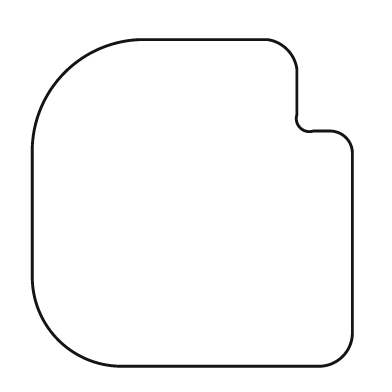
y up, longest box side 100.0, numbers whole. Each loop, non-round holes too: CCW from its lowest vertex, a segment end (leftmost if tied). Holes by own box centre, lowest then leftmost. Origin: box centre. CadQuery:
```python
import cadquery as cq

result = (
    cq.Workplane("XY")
    .moveTo(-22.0, -50.0)
    .lineTo(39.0, -50.0)
    .threePointArc((46.0, -47.0), (49.0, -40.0))
    .lineTo(49.0, 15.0)
    .threePointArc((47.0, 20.0), (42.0, 22.0))
    .lineTo(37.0, 22.0)
    .threePointArc((33.0, 23.0), (32.0, 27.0))
    .lineTo(32.0, 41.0)
    .threePointArc((29.0, 47.0), (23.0, 50.0))
    .lineTo(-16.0, 50.0)
    .threePointArc((-39.0, 40.0), (-49.0, 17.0))
    .lineTo(-49.0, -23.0)
    .threePointArc((-41.0, -42.0), (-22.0, -50.0))
    .close()
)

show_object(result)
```